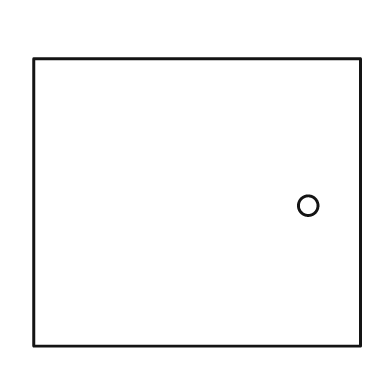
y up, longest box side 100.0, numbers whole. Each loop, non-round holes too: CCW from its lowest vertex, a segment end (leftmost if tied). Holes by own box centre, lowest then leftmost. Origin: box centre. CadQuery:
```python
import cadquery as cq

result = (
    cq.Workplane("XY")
    .moveTo(-50.0, -44.0)
    .lineTo(50.0, -44.0)
    .lineTo(50.0, 44.0)
    .lineTo(-50.0, 44.0)
    .close()
    .moveTo(34.0, -1.0)
    .circle(3.0)
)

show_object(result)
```